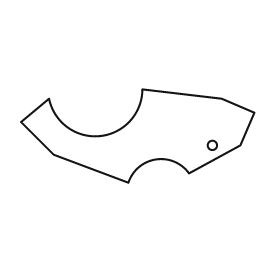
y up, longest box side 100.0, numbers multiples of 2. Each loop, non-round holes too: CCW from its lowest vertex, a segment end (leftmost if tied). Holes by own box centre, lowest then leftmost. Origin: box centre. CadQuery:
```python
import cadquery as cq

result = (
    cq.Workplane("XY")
    .moveTo(-4.0, -20.0)
    .threePointArc((8.0, -10.0), (22.0, -16.0))
    .lineTo(44.0, -4.0)
    .lineTo(50.0, 10.0)
    .lineTo(36.0, 16.0)
    .lineTo(2.0, 20.0)
    .threePointArc((-16.0, 0.0), (-38.0, 16.0))
    .lineTo(-50.0, 6.0)
    .lineTo(-36.0, -8.0)
    .close()
    .moveTo(32.0, -4.0)
    .circle(2.0)
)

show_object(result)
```